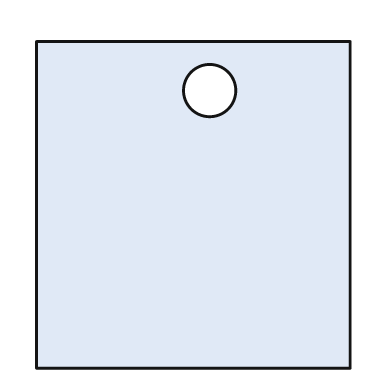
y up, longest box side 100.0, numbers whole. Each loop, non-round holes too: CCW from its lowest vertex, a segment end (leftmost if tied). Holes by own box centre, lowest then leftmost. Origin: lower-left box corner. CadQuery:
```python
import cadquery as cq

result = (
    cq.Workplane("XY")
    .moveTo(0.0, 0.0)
    .lineTo(96.0, 0.0)
    .lineTo(96.0, 100.0)
    .lineTo(0.0, 100.0)
    .close()
    .moveTo(53.0, 85.0)
    .circle(8.0)
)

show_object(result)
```